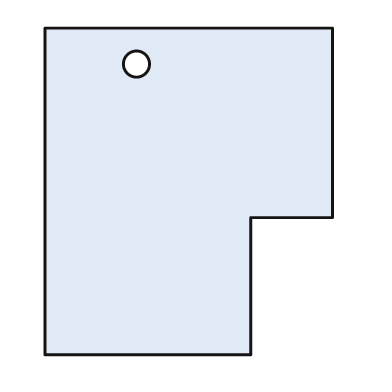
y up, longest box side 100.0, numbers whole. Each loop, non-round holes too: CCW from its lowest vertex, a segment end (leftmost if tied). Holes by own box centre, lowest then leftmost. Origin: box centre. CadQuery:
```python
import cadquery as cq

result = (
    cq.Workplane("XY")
    .moveTo(-44.0, -50.0)
    .lineTo(19.0, -50.0)
    .lineTo(19.0, -8.0)
    .lineTo(44.0, -8.0)
    .lineTo(44.0, 50.0)
    .lineTo(-44.0, 50.0)
    .close()
    .moveTo(-16.0, 39.0)
    .circle(4.0)
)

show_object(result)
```